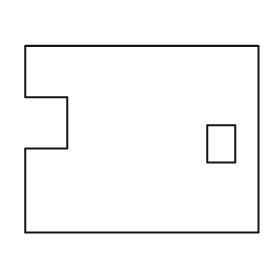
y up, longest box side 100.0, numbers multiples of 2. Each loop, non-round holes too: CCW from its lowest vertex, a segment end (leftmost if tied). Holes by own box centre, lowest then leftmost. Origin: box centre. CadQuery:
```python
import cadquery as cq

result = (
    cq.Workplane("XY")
    .moveTo(-50.0, -40.0)
    .lineTo(50.0, -40.0)
    .lineTo(50.0, 40.0)
    .lineTo(-50.0, 40.0)
    .lineTo(-50.0, 18.0)
    .lineTo(-32.0, 18.0)
    .lineTo(-32.0, -4.0)
    .lineTo(-50.0, -4.0)
    .close()
    .moveTo(28.0, -10.0)
    .lineTo(40.0, -10.0)
    .lineTo(40.0, 6.0)
    .lineTo(28.0, 6.0)
    .close()
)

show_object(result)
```